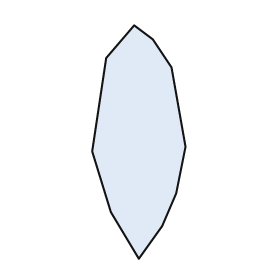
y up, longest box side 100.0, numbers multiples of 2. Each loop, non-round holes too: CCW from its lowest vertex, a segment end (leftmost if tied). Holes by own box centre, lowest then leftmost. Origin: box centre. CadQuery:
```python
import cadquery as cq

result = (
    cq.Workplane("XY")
    .moveTo(0.0, -50.0)
    .lineTo(10.0, -36.0)
    .lineTo(16.0, -22.0)
    .lineTo(20.0, -2.0)
    .lineTo(14.0, 32.0)
    .lineTo(6.0, 44.0)
    .lineTo(-2.0, 50.0)
    .lineTo(-14.0, 36.0)
    .lineTo(-20.0, -4.0)
    .lineTo(-12.0, -30.0)
    .close()
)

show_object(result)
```